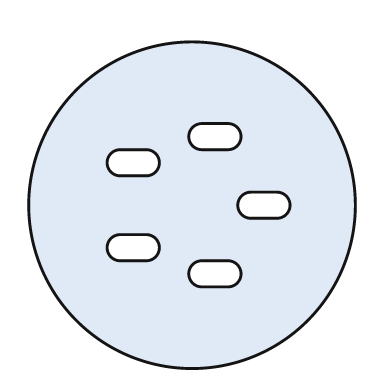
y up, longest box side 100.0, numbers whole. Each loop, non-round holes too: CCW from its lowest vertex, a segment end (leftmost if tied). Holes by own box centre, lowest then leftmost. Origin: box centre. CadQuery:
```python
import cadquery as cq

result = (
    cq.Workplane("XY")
    .moveTo(0.0, 0.0)
    .circle(50.0)
    .moveTo(3.0, -25.0)
    .lineTo(11.0, -25.0)
    .threePointArc((15.0, -21.0), (11.0, -17.0))
    .lineTo(3.0, -17.0)
    .threePointArc((-1.0, -21.0), (3.0, -25.0))
    .close()
    .moveTo(-22.0, -17.0)
    .lineTo(-14.0, -17.0)
    .threePointArc((-10.0, -13.0), (-14.0, -9.0))
    .lineTo(-22.0, -9.0)
    .threePointArc((-26.0, -13.0), (-22.0, -17.0))
    .close()
    .moveTo(18.0, -4.0)
    .lineTo(26.0, -4.0)
    .threePointArc((30.0, 0.0), (26.0, 4.0))
    .lineTo(18.0, 4.0)
    .threePointArc((14.0, 0.0), (18.0, -4.0))
    .close()
    .moveTo(-22.0, 9.0)
    .lineTo(-14.0, 9.0)
    .threePointArc((-10.0, 13.0), (-14.0, 17.0))
    .lineTo(-22.0, 17.0)
    .threePointArc((-26.0, 13.0), (-22.0, 9.0))
    .close()
    .moveTo(3.0, 17.0)
    .lineTo(11.0, 17.0)
    .threePointArc((15.0, 21.0), (11.0, 25.0))
    .lineTo(3.0, 25.0)
    .threePointArc((-1.0, 21.0), (3.0, 17.0))
    .close()
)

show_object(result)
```